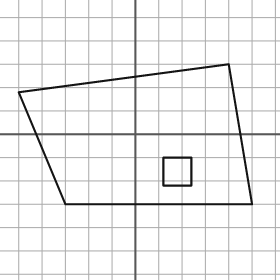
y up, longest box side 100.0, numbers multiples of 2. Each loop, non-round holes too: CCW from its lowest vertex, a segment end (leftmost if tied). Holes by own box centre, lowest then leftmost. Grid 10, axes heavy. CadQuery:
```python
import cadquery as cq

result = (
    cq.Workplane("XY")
    .moveTo(-30.0, -30.0)
    .lineTo(50.0, -30.0)
    .lineTo(40.0, 30.0)
    .lineTo(-50.0, 18.0)
    .close()
    .moveTo(12.0, -22.0)
    .lineTo(24.0, -22.0)
    .lineTo(24.0, -10.0)
    .lineTo(12.0, -10.0)
    .close()
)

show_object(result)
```